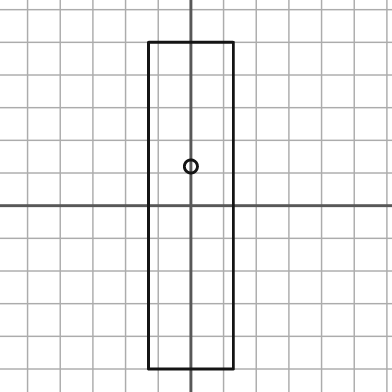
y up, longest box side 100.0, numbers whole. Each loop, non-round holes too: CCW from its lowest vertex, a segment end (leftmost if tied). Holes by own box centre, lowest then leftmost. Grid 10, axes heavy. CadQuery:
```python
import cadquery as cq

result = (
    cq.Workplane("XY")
    .moveTo(-13.0, -50.0)
    .lineTo(13.0, -50.0)
    .lineTo(13.0, 50.0)
    .lineTo(-13.0, 50.0)
    .close()
    .moveTo(0.0, 12.0)
    .circle(2.0)
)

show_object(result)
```